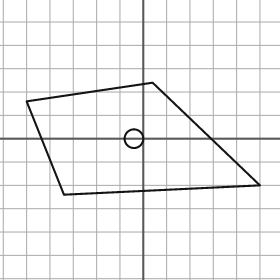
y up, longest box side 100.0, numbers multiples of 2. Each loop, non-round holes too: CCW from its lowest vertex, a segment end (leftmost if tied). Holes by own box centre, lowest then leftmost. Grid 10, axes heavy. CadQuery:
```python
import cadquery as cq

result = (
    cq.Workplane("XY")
    .moveTo(-34.0, -24.0)
    .lineTo(50.0, -20.0)
    .lineTo(4.0, 24.0)
    .lineTo(-50.0, 16.0)
    .close()
    .moveTo(-4.0, 0.0)
    .circle(4.0)
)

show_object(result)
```